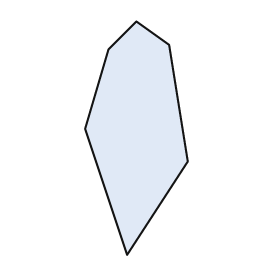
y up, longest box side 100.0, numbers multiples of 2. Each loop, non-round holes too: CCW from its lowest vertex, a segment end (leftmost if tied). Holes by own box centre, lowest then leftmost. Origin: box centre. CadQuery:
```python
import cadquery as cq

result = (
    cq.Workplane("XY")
    .moveTo(-4.0, -50.0)
    .lineTo(22.0, -10.0)
    .lineTo(14.0, 40.0)
    .lineTo(0.0, 50.0)
    .lineTo(-12.0, 38.0)
    .lineTo(-22.0, 4.0)
    .close()
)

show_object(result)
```